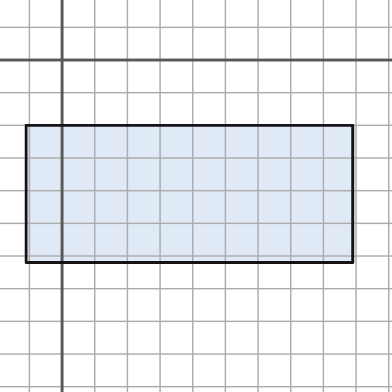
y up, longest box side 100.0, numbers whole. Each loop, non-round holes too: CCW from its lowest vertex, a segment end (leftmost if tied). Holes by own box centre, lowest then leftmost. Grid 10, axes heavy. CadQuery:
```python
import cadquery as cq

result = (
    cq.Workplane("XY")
    .moveTo(-11.0, -62.0)
    .lineTo(89.0, -62.0)
    .lineTo(89.0, -20.0)
    .lineTo(-11.0, -20.0)
    .close()
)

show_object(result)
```